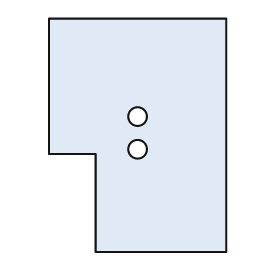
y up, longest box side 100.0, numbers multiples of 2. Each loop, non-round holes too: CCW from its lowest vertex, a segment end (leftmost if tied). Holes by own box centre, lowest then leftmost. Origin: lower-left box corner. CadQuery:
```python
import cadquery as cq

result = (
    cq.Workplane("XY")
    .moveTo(20.0, 0.0)
    .lineTo(76.0, 0.0)
    .lineTo(76.0, 100.0)
    .lineTo(0.0, 100.0)
    .lineTo(0.0, 42.0)
    .lineTo(20.0, 42.0)
    .close()
    .moveTo(38.0, 44.0)
    .circle(4.0)
    .moveTo(38.0, 58.0)
    .circle(4.0)
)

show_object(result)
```